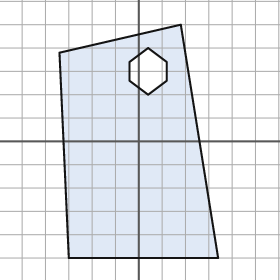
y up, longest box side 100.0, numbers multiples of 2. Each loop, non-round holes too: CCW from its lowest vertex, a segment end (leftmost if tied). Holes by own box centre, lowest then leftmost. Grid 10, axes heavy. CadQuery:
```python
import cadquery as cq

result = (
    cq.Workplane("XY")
    .moveTo(-30.0, -50.0)
    .lineTo(34.0, -50.0)
    .lineTo(18.0, 50.0)
    .lineTo(-34.0, 38.0)
    .close()
    .moveTo(4.0, 20.0)
    .lineTo(12.0, 26.0)
    .lineTo(12.0, 34.0)
    .lineTo(4.0, 40.0)
    .lineTo(-4.0, 34.0)
    .lineTo(-4.0, 26.0)
    .close()
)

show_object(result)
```